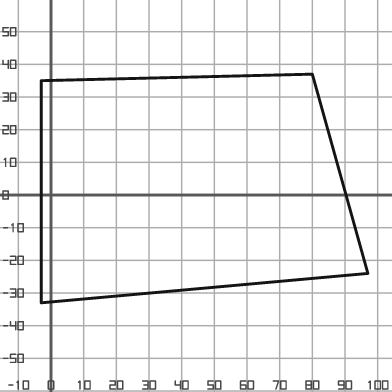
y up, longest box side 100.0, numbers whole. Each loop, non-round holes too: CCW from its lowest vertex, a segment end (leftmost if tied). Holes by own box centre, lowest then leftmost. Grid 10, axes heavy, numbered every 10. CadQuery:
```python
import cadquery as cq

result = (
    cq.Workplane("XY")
    .moveTo(-3.0, -33.0)
    .lineTo(97.0, -24.0)
    .lineTo(80.0, 37.0)
    .lineTo(-3.0, 35.0)
    .close()
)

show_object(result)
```